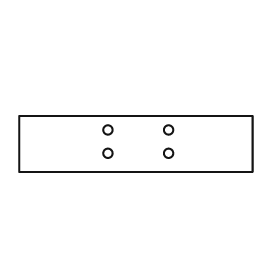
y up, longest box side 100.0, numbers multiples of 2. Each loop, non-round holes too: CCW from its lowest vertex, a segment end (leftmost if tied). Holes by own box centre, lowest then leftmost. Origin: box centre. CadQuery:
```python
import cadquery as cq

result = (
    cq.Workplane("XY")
    .moveTo(-50.0, -12.0)
    .lineTo(50.0, -12.0)
    .lineTo(50.0, 12.0)
    .lineTo(-50.0, 12.0)
    .close()
    .moveTo(-12.0, -4.0)
    .circle(2.0)
    .moveTo(14.0, -4.0)
    .circle(2.0)
    .moveTo(-12.0, 6.0)
    .circle(2.0)
    .moveTo(14.0, 6.0)
    .circle(2.0)
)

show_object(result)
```